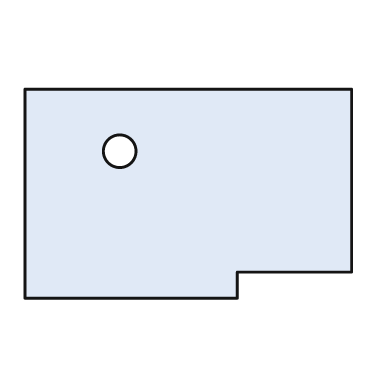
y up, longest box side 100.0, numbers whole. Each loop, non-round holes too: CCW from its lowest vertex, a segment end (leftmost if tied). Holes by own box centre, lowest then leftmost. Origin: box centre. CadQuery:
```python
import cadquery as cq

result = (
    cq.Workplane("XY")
    .moveTo(-50.0, -32.0)
    .lineTo(15.0, -32.0)
    .lineTo(15.0, -24.0)
    .lineTo(50.0, -24.0)
    .lineTo(50.0, 32.0)
    .lineTo(-50.0, 32.0)
    .close()
    .moveTo(-21.0, 13.0)
    .circle(5.0)
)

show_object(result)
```